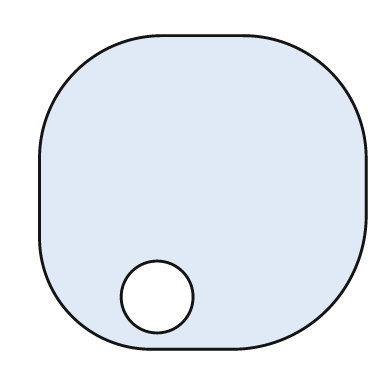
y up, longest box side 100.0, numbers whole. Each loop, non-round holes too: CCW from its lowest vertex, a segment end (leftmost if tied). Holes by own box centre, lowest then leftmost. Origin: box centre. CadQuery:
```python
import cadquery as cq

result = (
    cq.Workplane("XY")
    .moveTo(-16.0, -48.0)
    .lineTo(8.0, -48.0)
    .threePointArc((38.0, -36.0), (50.0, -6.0))
    .lineTo(50.0, 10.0)
    .threePointArc((39.0, 37.0), (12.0, 48.0))
    .lineTo(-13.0, 48.0)
    .threePointArc((-39.0, 37.0), (-50.0, 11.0))
    .lineTo(-50.0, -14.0)
    .threePointArc((-40.0, -38.0), (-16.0, -48.0))
    .close()
    .moveTo(-14.0, -32.0)
    .circle(11.0)
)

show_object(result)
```